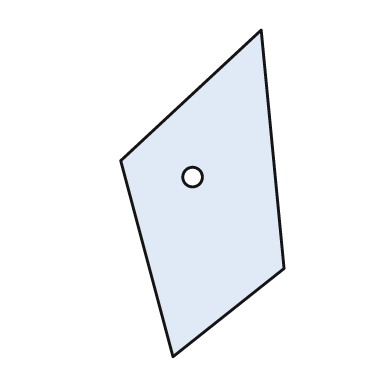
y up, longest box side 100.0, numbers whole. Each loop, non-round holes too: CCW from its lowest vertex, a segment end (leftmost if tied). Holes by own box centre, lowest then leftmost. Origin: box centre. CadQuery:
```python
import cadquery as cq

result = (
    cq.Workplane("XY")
    .moveTo(-9.0, -50.0)
    .lineTo(25.0, -23.0)
    .lineTo(18.0, 50.0)
    .lineTo(-25.0, 10.0)
    .close()
    .moveTo(-3.0, 5.0)
    .circle(3.0)
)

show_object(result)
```